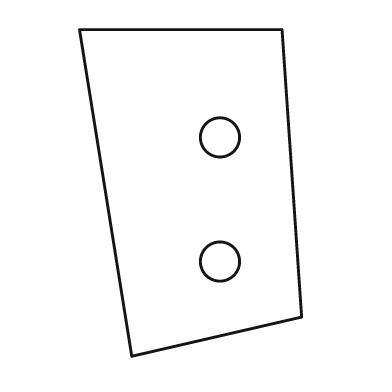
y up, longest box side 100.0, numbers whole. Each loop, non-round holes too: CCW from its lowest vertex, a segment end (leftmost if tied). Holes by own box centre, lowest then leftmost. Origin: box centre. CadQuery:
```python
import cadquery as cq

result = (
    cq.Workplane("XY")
    .moveTo(-18.0, -50.0)
    .lineTo(34.0, -38.0)
    .lineTo(28.0, 50.0)
    .lineTo(-34.0, 50.0)
    .close()
    .moveTo(9.0, -21.0)
    .circle(6.0)
    .moveTo(9.0, 17.0)
    .circle(6.0)
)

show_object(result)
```